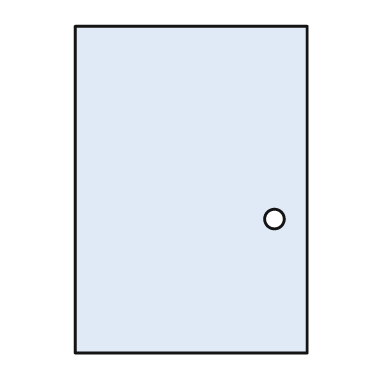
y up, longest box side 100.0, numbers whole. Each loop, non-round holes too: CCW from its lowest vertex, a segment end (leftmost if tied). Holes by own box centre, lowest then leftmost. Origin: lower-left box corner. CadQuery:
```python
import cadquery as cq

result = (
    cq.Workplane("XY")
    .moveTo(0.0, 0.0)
    .lineTo(71.0, 0.0)
    .lineTo(71.0, 100.0)
    .lineTo(0.0, 100.0)
    .close()
    .moveTo(61.0, 41.0)
    .circle(3.0)
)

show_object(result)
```